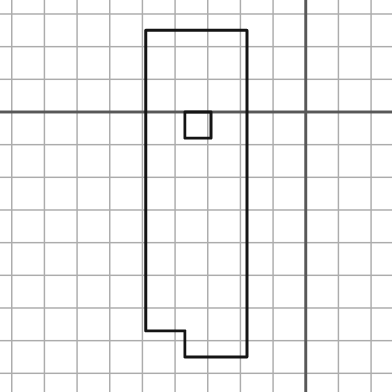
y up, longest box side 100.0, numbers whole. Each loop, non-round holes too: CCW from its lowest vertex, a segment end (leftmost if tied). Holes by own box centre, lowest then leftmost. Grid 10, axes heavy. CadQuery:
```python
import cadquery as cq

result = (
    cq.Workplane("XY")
    .moveTo(-37.0, -75.0)
    .lineTo(-18.0, -75.0)
    .lineTo(-18.0, 25.0)
    .lineTo(-49.0, 25.0)
    .lineTo(-49.0, -67.0)
    .lineTo(-37.0, -67.0)
    .close()
    .moveTo(-37.0, -8.0)
    .lineTo(-29.0, -8.0)
    .lineTo(-29.0, 0.0)
    .lineTo(-37.0, 0.0)
    .close()
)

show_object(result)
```